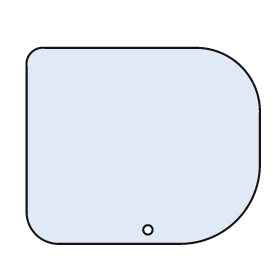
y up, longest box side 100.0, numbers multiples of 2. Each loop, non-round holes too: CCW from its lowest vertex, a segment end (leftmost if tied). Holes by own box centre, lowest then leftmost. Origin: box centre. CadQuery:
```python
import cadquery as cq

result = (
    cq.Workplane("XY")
    .moveTo(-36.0, -42.0)
    .lineTo(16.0, -42.0)
    .threePointArc((40.0, -32.0), (50.0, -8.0))
    .lineTo(50.0, 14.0)
    .threePointArc((42.0, 34.0), (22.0, 42.0))
    .lineTo(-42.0, 42.0)
    .threePointArc((-48.0, 40.0), (-50.0, 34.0))
    .lineTo(-50.0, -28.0)
    .threePointArc((-46.0, -38.0), (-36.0, -42.0))
    .close()
    .moveTo(2.0, -36.0)
    .circle(2.0)
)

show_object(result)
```